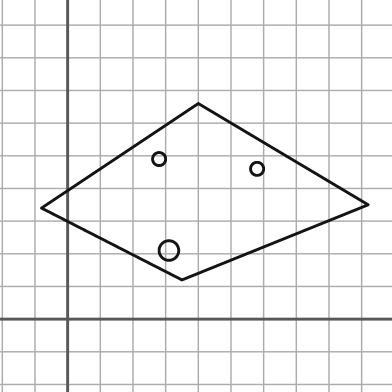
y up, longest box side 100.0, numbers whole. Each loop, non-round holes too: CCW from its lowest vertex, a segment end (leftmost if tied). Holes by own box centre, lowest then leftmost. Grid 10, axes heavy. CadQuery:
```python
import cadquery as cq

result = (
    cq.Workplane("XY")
    .moveTo(35.0, 12.0)
    .lineTo(92.0, 35.0)
    .lineTo(40.0, 66.0)
    .lineTo(-8.0, 34.0)
    .close()
    .moveTo(31.0, 21.0)
    .circle(3.0)
    .moveTo(58.0, 46.0)
    .circle(2.0)
    .moveTo(28.0, 49.0)
    .circle(2.0)
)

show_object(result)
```